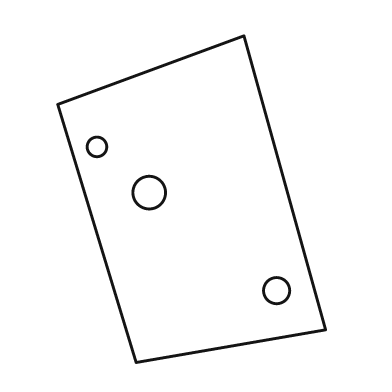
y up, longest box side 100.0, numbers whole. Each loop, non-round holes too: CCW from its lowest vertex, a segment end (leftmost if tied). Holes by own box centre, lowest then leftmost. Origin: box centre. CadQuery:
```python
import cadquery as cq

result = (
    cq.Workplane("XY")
    .moveTo(-17.0, -50.0)
    .lineTo(41.0, -40.0)
    .lineTo(16.0, 50.0)
    .lineTo(-41.0, 29.0)
    .close()
    .moveTo(26.0, -28.0)
    .circle(4.0)
    .moveTo(-13.0, 2.0)
    .circle(5.0)
    .moveTo(-29.0, 16.0)
    .circle(3.0)
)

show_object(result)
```